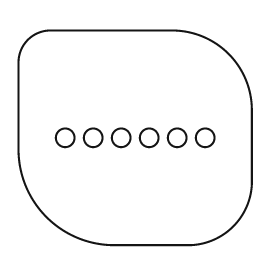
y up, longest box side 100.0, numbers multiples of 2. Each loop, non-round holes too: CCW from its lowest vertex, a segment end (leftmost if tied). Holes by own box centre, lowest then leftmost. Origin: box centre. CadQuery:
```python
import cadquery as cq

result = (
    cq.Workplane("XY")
    .moveTo(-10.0, -46.0)
    .lineTo(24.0, -46.0)
    .threePointArc((42.0, -38.0), (50.0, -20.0))
    .lineTo(50.0, 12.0)
    .threePointArc((40.0, 36.0), (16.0, 46.0))
    .lineTo(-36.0, 46.0)
    .threePointArc((-46.0, 42.0), (-50.0, 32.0))
    .lineTo(-50.0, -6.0)
    .threePointArc((-38.0, -34.0), (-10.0, -46.0))
    .close()
    .moveTo(-30.0, 0.0)
    .circle(4.0)
    .moveTo(-18.0, 0.0)
    .circle(4.0)
    .moveTo(-6.0, 0.0)
    .circle(4.0)
    .moveTo(6.0, 0.0)
    .circle(4.0)
    .moveTo(18.0, 0.0)
    .circle(4.0)
    .moveTo(30.0, 0.0)
    .circle(4.0)
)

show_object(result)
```